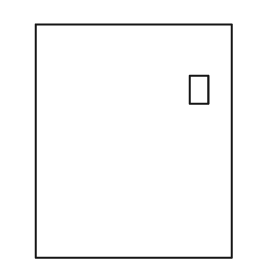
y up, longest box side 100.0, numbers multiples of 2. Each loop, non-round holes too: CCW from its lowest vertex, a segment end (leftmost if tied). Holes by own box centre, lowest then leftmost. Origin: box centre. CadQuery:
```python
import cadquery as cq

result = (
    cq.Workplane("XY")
    .moveTo(-42.0, -50.0)
    .lineTo(42.0, -50.0)
    .lineTo(42.0, 50.0)
    .lineTo(-42.0, 50.0)
    .close()
    .moveTo(24.0, 16.0)
    .lineTo(32.0, 16.0)
    .lineTo(32.0, 28.0)
    .lineTo(24.0, 28.0)
    .close()
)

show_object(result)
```